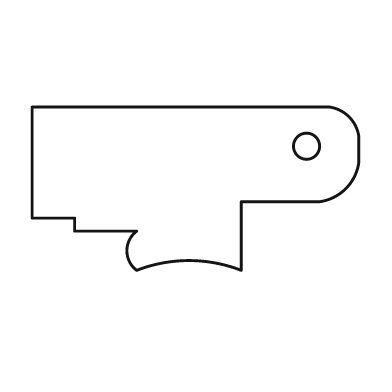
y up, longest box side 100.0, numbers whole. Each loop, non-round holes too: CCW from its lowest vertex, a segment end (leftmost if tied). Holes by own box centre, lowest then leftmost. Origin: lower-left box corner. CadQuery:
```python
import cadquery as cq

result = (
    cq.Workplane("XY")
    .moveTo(32.0, 0.0)
    .threePointArc((48.0, 3.0), (64.0, 0.0))
    .lineTo(64.0, 21.0)
    .lineTo(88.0, 21.0)
    .threePointArc((96.0, 25.0), (100.0, 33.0))
    .lineTo(100.0, 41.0)
    .threePointArc((97.0, 47.0), (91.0, 50.0))
    .lineTo(0.0, 50.0)
    .lineTo(0.0, 16.0)
    .lineTo(13.0, 16.0)
    .lineTo(13.0, 12.0)
    .lineTo(32.0, 12.0)
    .threePointArc((29.0, 6.0), (32.0, 0.0))
    .close()
    .moveTo(84.0, 38.0)
    .circle(4.0)
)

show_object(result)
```